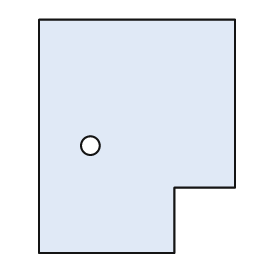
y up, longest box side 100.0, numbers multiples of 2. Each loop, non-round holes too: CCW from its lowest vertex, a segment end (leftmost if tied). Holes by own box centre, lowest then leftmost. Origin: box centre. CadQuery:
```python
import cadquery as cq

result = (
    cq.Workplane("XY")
    .moveTo(-42.0, -50.0)
    .lineTo(16.0, -50.0)
    .lineTo(16.0, -22.0)
    .lineTo(42.0, -22.0)
    .lineTo(42.0, 50.0)
    .lineTo(-42.0, 50.0)
    .close()
    .moveTo(-20.0, -4.0)
    .circle(4.0)
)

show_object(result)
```